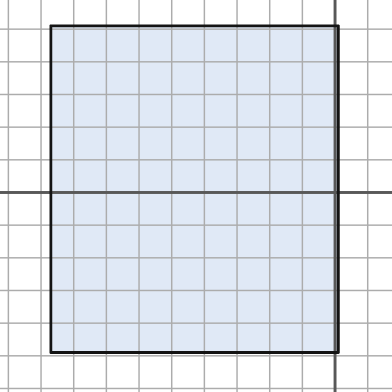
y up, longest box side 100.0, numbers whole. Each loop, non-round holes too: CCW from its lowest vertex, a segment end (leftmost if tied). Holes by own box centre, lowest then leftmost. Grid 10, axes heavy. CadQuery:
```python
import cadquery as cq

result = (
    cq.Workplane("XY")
    .moveTo(-87.0, -49.0)
    .lineTo(1.0, -49.0)
    .lineTo(1.0, 51.0)
    .lineTo(-87.0, 51.0)
    .close()
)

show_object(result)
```